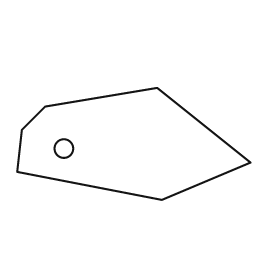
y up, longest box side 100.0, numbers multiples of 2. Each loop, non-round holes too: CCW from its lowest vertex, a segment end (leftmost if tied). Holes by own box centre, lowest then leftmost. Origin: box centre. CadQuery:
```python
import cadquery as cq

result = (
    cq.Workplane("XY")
    .moveTo(12.0, -24.0)
    .lineTo(50.0, -8.0)
    .lineTo(10.0, 24.0)
    .lineTo(-38.0, 16.0)
    .lineTo(-48.0, 6.0)
    .lineTo(-50.0, -12.0)
    .close()
    .moveTo(-30.0, -2.0)
    .circle(4.0)
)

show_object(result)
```